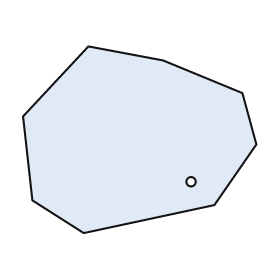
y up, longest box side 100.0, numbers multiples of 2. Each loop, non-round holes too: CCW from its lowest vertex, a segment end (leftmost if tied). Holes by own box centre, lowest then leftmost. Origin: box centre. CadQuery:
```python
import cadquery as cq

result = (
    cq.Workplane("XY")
    .moveTo(-24.0, -40.0)
    .lineTo(32.0, -28.0)
    .lineTo(50.0, -2.0)
    .lineTo(44.0, 20.0)
    .lineTo(10.0, 34.0)
    .lineTo(-22.0, 40.0)
    .lineTo(-50.0, 10.0)
    .lineTo(-46.0, -26.0)
    .close()
    .moveTo(22.0, -18.0)
    .circle(2.0)
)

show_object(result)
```